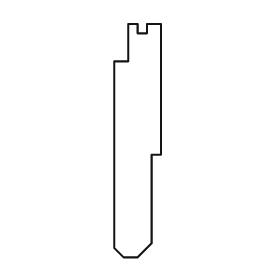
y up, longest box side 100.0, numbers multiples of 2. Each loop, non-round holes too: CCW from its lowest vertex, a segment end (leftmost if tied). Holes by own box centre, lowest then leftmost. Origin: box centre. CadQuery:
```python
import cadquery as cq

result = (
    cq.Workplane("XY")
    .moveTo(-6.0, -50.0)
    .lineTo(0.0, -50.0)
    .lineTo(6.0, -44.0)
    .lineTo(6.0, -6.0)
    .lineTo(10.0, -6.0)
    .lineTo(10.0, 50.0)
    .lineTo(4.0, 50.0)
    .lineTo(4.0, 46.0)
    .lineTo(0.0, 46.0)
    .lineTo(0.0, 50.0)
    .lineTo(-4.0, 50.0)
    .lineTo(-4.0, 34.0)
    .lineTo(-10.0, 34.0)
    .lineTo(-10.0, -46.0)
    .close()
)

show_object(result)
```